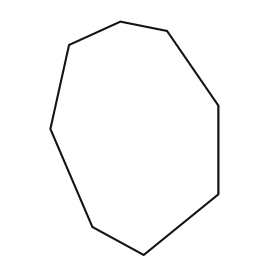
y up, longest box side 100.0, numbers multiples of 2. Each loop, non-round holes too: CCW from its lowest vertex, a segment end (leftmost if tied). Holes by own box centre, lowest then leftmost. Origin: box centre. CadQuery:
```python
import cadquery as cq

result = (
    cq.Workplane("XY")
    .moveTo(4.0, -50.0)
    .lineTo(36.0, -24.0)
    .lineTo(36.0, 14.0)
    .lineTo(14.0, 46.0)
    .lineTo(-6.0, 50.0)
    .lineTo(-28.0, 40.0)
    .lineTo(-36.0, 4.0)
    .lineTo(-18.0, -38.0)
    .close()
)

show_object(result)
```